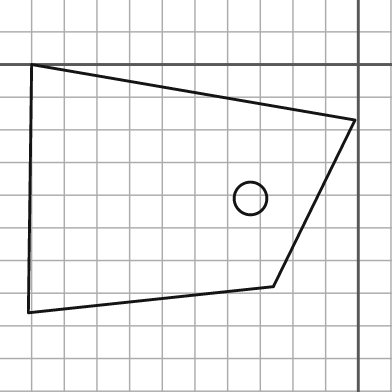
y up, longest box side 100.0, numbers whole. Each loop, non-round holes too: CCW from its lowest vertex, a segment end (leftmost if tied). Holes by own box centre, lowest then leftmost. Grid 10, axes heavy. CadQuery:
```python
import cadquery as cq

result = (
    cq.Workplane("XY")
    .moveTo(-101.0, -76.0)
    .lineTo(-26.0, -68.0)
    .lineTo(-1.0, -17.0)
    .lineTo(-100.0, 0.0)
    .close()
    .moveTo(-33.0, -41.0)
    .circle(5.0)
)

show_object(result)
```